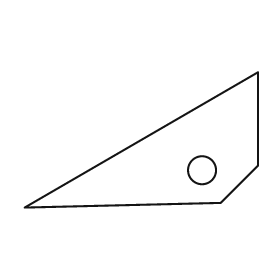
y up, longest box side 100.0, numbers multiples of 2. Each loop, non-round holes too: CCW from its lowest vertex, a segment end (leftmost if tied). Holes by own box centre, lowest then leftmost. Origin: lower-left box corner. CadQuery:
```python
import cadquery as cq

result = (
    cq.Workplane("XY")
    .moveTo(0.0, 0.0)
    .lineTo(84.0, 2.0)
    .lineTo(100.0, 18.0)
    .lineTo(100.0, 58.0)
    .close()
    .moveTo(76.0, 16.0)
    .circle(6.0)
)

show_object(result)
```